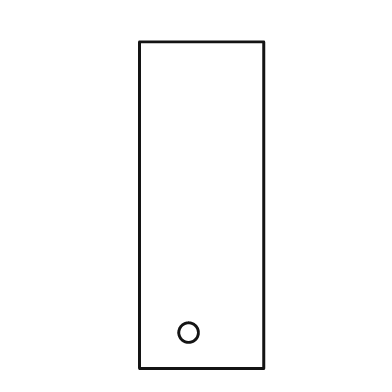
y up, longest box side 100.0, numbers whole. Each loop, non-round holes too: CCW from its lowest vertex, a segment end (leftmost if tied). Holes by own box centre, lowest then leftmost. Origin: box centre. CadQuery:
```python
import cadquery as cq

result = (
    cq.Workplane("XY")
    .moveTo(-19.0, -50.0)
    .lineTo(19.0, -50.0)
    .lineTo(19.0, 50.0)
    .lineTo(-19.0, 50.0)
    .close()
    .moveTo(-4.0, -39.0)
    .circle(3.0)
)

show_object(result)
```